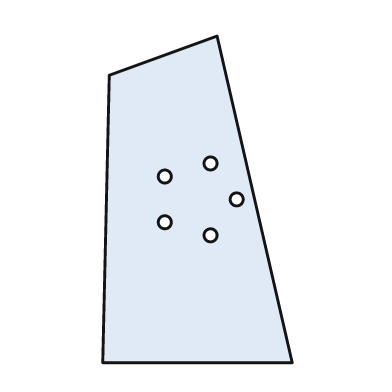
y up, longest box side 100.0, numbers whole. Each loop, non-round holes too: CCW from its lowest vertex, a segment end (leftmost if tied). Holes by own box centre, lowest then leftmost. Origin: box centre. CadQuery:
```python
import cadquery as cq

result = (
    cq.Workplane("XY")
    .moveTo(-29.0, -50.0)
    .lineTo(29.0, -50.0)
    .lineTo(6.0, 50.0)
    .lineTo(-27.0, 38.0)
    .close()
    .moveTo(4.0, -11.0)
    .circle(2.0)
    .moveTo(-10.0, -7.0)
    .circle(2.0)
    .moveTo(12.0, 0.0)
    .circle(2.0)
    .moveTo(-10.0, 7.0)
    .circle(2.0)
    .moveTo(4.0, 11.0)
    .circle(2.0)
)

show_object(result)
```